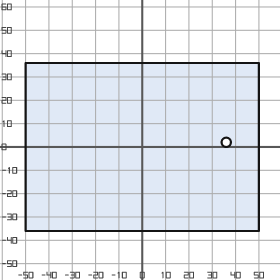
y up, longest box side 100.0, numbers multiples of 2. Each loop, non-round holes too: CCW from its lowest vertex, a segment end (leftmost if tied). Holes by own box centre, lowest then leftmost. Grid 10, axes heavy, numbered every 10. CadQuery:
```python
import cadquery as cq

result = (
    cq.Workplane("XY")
    .moveTo(-50.0, -36.0)
    .lineTo(50.0, -36.0)
    .lineTo(50.0, 36.0)
    .lineTo(-50.0, 36.0)
    .close()
    .moveTo(36.0, 2.0)
    .circle(2.0)
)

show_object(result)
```